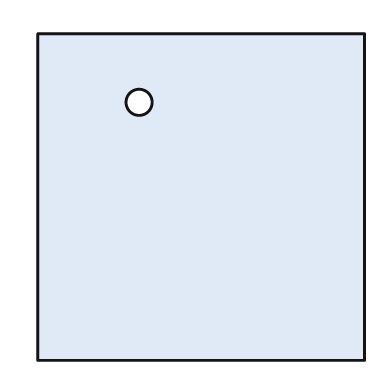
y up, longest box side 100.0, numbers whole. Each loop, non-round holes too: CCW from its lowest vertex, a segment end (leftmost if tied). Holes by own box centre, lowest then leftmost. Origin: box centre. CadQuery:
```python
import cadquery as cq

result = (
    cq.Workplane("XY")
    .moveTo(-50.0, -50.0)
    .lineTo(50.0, -50.0)
    .lineTo(50.0, 50.0)
    .lineTo(-50.0, 50.0)
    .close()
    .moveTo(-19.0, 29.0)
    .circle(4.0)
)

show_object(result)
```